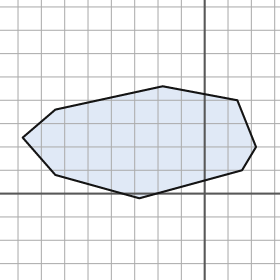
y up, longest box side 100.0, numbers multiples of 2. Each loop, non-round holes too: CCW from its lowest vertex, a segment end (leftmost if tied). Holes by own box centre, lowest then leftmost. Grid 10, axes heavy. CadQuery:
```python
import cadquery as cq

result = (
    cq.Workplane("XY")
    .moveTo(-28.0, -2.0)
    .lineTo(16.0, 10.0)
    .lineTo(22.0, 20.0)
    .lineTo(14.0, 40.0)
    .lineTo(-18.0, 46.0)
    .lineTo(-64.0, 36.0)
    .lineTo(-78.0, 24.0)
    .lineTo(-64.0, 8.0)
    .close()
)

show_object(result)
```